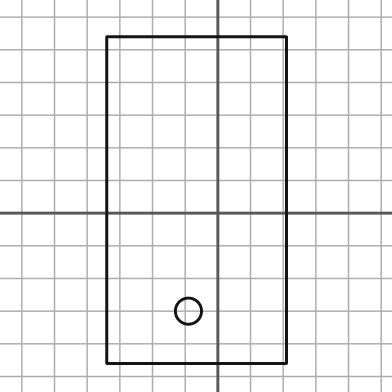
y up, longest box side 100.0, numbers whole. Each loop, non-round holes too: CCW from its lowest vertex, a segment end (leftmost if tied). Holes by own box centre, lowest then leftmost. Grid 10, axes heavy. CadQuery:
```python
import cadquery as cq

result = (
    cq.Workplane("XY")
    .moveTo(-34.0, -46.0)
    .lineTo(21.0, -46.0)
    .lineTo(21.0, 54.0)
    .lineTo(-34.0, 54.0)
    .close()
    .moveTo(-9.0, -30.0)
    .circle(4.0)
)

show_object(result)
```